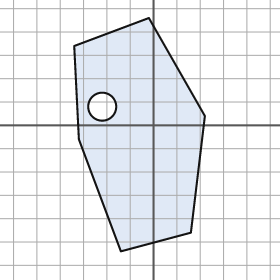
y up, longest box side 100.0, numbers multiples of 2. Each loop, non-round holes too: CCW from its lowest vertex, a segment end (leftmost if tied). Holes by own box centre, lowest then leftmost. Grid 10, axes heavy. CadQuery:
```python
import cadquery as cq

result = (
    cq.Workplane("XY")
    .moveTo(-14.0, -54.0)
    .lineTo(16.0, -46.0)
    .lineTo(22.0, 4.0)
    .lineTo(-2.0, 46.0)
    .lineTo(-34.0, 34.0)
    .lineTo(-32.0, -6.0)
    .close()
    .moveTo(-22.0, 8.0)
    .circle(6.0)
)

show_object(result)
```